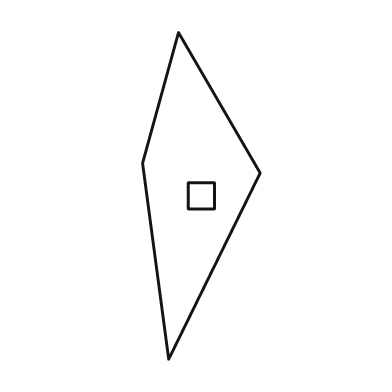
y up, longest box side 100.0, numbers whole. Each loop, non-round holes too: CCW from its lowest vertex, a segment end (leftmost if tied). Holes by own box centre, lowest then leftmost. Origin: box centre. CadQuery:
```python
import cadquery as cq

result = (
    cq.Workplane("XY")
    .moveTo(-10.0, -50.0)
    .lineTo(18.0, 7.0)
    .lineTo(-7.0, 50.0)
    .lineTo(-18.0, 10.0)
    .close()
    .moveTo(-4.0, -4.0)
    .lineTo(4.0, -4.0)
    .lineTo(4.0, 4.0)
    .lineTo(-4.0, 4.0)
    .close()
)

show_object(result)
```